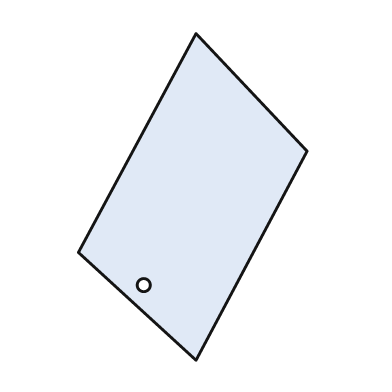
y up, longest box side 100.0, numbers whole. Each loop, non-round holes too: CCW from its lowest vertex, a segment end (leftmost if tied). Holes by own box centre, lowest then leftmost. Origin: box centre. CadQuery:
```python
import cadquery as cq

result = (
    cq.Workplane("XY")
    .moveTo(1.0, -50.0)
    .lineTo(35.0, 14.0)
    .lineTo(1.0, 50.0)
    .lineTo(-35.0, -17.0)
    .close()
    .moveTo(-15.0, -27.0)
    .circle(2.0)
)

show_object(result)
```